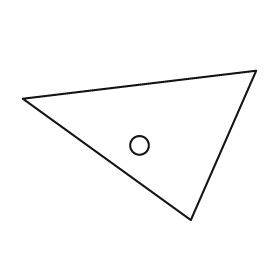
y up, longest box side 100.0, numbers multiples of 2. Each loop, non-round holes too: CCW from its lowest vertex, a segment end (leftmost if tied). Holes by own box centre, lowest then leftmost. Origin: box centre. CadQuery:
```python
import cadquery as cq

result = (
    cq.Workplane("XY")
    .moveTo(22.0, -32.0)
    .lineTo(50.0, 32.0)
    .lineTo(-50.0, 20.0)
    .close()
    .moveTo(0.0, 0.0)
    .circle(4.0)
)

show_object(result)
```